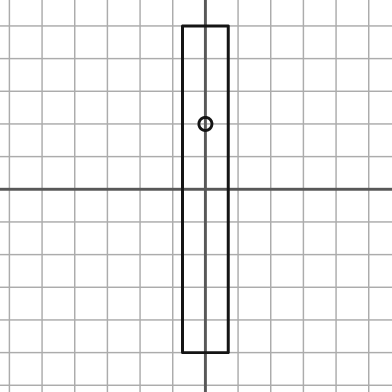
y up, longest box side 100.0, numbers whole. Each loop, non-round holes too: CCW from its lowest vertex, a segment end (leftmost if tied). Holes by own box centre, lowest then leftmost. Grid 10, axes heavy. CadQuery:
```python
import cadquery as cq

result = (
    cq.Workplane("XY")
    .moveTo(-7.0, -50.0)
    .lineTo(7.0, -50.0)
    .lineTo(7.0, 50.0)
    .lineTo(-7.0, 50.0)
    .close()
    .moveTo(0.0, 20.0)
    .circle(2.0)
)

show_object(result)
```